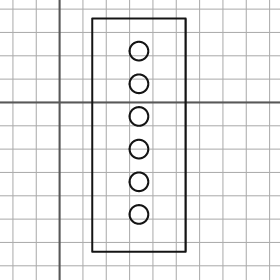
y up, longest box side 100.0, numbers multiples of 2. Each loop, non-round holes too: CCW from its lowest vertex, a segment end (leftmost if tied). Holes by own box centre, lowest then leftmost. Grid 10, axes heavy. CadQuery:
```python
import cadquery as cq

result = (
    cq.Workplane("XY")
    .moveTo(14.0, -64.0)
    .lineTo(54.0, -64.0)
    .lineTo(54.0, 36.0)
    .lineTo(14.0, 36.0)
    .close()
    .moveTo(34.0, -48.0)
    .circle(4.0)
    .moveTo(34.0, -34.0)
    .circle(4.0)
    .moveTo(34.0, -20.0)
    .circle(4.0)
    .moveTo(34.0, -6.0)
    .circle(4.0)
    .moveTo(34.0, 8.0)
    .circle(4.0)
    .moveTo(34.0, 22.0)
    .circle(4.0)
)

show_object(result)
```